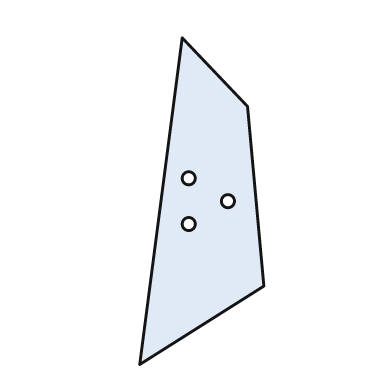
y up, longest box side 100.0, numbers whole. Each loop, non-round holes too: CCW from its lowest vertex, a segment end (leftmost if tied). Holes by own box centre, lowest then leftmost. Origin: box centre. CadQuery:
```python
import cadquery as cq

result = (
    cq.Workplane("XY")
    .moveTo(-19.0, -50.0)
    .lineTo(19.0, -26.0)
    .lineTo(14.0, 29.0)
    .lineTo(-6.0, 50.0)
    .close()
    .moveTo(-4.0, -7.0)
    .circle(2.0)
    .moveTo(8.0, 0.0)
    .circle(2.0)
    .moveTo(-4.0, 7.0)
    .circle(2.0)
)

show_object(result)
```